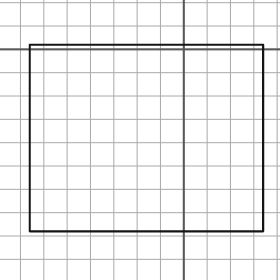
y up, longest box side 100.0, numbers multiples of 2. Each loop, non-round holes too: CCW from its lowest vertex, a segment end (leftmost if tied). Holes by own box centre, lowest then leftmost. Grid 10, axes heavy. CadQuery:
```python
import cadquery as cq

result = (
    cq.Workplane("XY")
    .moveTo(-66.0, -78.0)
    .lineTo(34.0, -78.0)
    .lineTo(34.0, 2.0)
    .lineTo(-66.0, 2.0)
    .close()
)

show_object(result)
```